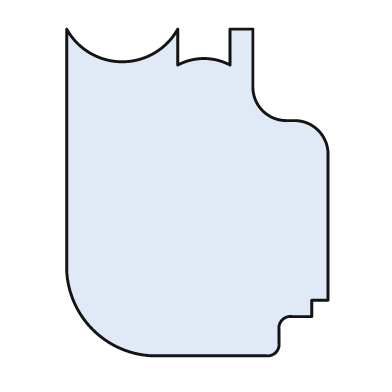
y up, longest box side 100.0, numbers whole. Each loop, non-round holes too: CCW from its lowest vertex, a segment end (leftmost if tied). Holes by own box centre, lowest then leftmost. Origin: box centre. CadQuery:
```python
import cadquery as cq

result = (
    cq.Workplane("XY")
    .moveTo(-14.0, -50.0)
    .lineTo(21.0, -50.0)
    .threePointArc((24.0, -49.0), (25.0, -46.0))
    .lineTo(25.0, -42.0)
    .threePointArc((26.0, -39.0), (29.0, -38.0))
    .lineTo(35.0, -38.0)
    .lineTo(35.0, -33.0)
    .lineTo(40.0, -33.0)
    .lineTo(40.0, 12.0)
    .threePointArc((37.0, 19.0), (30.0, 22.0))
    .lineTo(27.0, 22.0)
    .threePointArc((20.0, 25.0), (17.0, 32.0))
    .lineTo(17.0, 50.0)
    .lineTo(10.0, 50.0)
    .lineTo(10.0, 39.0)
    .threePointArc((2.0, 41.0), (-6.0, 39.0))
    .lineTo(-6.0, 50.0)
    .threePointArc((-23.0, 40.0), (-40.0, 50.0))
    .lineTo(-40.0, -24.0)
    .threePointArc((-32.0, -42.0), (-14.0, -50.0))
    .close()
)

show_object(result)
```